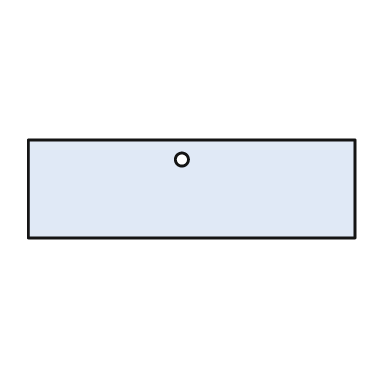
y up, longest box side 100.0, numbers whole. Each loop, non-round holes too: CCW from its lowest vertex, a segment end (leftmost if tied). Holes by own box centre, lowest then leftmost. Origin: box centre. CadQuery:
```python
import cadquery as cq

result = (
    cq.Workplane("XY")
    .moveTo(-50.0, -15.0)
    .lineTo(50.0, -15.0)
    .lineTo(50.0, 15.0)
    .lineTo(-50.0, 15.0)
    .close()
    .moveTo(-3.0, 9.0)
    .circle(2.0)
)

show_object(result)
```